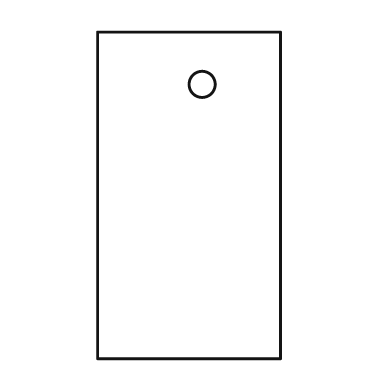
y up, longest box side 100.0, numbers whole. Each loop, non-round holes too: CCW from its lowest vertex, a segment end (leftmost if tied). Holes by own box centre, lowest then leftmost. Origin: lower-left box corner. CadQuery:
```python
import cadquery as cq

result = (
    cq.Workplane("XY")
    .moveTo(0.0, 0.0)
    .lineTo(56.0, 0.0)
    .lineTo(56.0, 100.0)
    .lineTo(0.0, 100.0)
    .close()
    .moveTo(32.0, 84.0)
    .circle(4.0)
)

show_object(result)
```